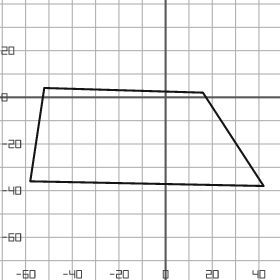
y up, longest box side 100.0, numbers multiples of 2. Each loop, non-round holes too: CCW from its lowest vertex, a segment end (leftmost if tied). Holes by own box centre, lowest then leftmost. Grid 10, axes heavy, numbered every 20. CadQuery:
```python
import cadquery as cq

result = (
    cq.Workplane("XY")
    .moveTo(42.0, -38.0)
    .lineTo(16.0, 2.0)
    .lineTo(-52.0, 4.0)
    .lineTo(-58.0, -36.0)
    .close()
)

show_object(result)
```